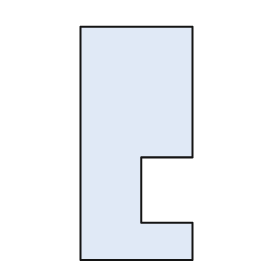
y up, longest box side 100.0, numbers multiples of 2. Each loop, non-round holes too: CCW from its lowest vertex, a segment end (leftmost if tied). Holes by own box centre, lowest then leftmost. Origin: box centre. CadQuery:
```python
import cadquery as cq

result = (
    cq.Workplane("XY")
    .moveTo(-24.0, -50.0)
    .lineTo(24.0, -50.0)
    .lineTo(24.0, -34.0)
    .lineTo(2.0, -34.0)
    .lineTo(2.0, -6.0)
    .lineTo(24.0, -6.0)
    .lineTo(24.0, 50.0)
    .lineTo(-24.0, 50.0)
    .close()
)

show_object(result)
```